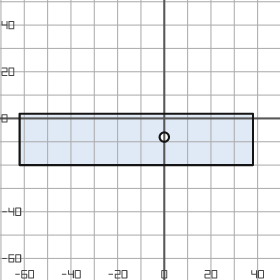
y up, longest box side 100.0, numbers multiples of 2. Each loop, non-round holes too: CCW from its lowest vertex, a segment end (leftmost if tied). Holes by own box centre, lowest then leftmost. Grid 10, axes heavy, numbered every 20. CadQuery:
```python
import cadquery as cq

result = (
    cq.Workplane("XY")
    .moveTo(-62.0, -20.0)
    .lineTo(38.0, -20.0)
    .lineTo(38.0, 2.0)
    .lineTo(-62.0, 2.0)
    .close()
    .moveTo(0.0, -8.0)
    .circle(2.0)
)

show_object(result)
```